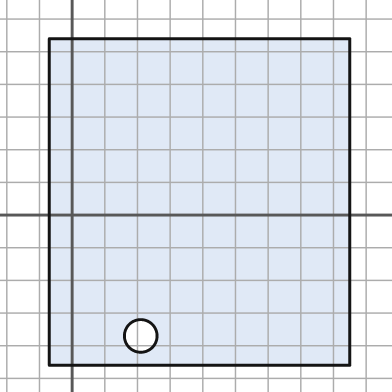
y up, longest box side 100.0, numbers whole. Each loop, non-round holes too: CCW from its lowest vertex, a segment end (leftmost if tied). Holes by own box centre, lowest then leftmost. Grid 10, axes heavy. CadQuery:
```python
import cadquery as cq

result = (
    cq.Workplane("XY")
    .moveTo(-7.0, -46.0)
    .lineTo(85.0, -46.0)
    .lineTo(85.0, 54.0)
    .lineTo(-7.0, 54.0)
    .close()
    .moveTo(21.0, -37.0)
    .circle(5.0)
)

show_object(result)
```